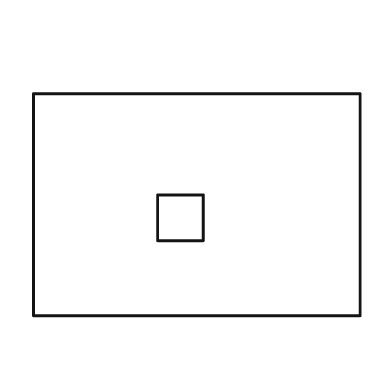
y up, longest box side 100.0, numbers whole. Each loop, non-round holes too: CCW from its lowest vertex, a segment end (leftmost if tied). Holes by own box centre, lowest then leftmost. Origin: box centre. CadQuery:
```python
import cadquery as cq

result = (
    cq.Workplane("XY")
    .moveTo(-50.0, -34.0)
    .lineTo(50.0, -34.0)
    .lineTo(50.0, 34.0)
    .lineTo(-50.0, 34.0)
    .close()
    .moveTo(-12.0, -11.0)
    .lineTo(2.0, -11.0)
    .lineTo(2.0, 3.0)
    .lineTo(-12.0, 3.0)
    .close()
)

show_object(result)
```